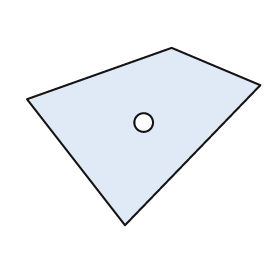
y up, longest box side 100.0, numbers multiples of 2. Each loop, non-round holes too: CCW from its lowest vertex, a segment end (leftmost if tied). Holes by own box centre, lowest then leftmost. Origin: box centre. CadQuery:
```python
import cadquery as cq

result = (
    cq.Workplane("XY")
    .moveTo(-8.0, -38.0)
    .lineTo(50.0, 22.0)
    .lineTo(12.0, 38.0)
    .lineTo(-50.0, 16.0)
    .close()
    .moveTo(0.0, 6.0)
    .circle(4.0)
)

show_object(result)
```